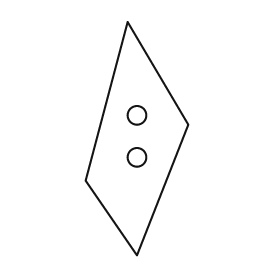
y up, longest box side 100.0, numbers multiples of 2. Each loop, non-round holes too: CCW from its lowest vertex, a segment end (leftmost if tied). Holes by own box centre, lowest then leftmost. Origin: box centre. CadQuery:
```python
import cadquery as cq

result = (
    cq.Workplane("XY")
    .moveTo(0.0, -50.0)
    .lineTo(22.0, 6.0)
    .lineTo(-4.0, 50.0)
    .lineTo(-22.0, -18.0)
    .close()
    .moveTo(0.0, -8.0)
    .circle(4.0)
    .moveTo(0.0, 10.0)
    .circle(4.0)
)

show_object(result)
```